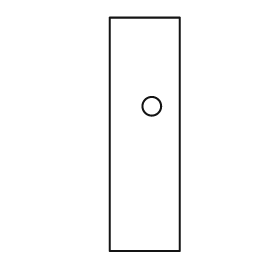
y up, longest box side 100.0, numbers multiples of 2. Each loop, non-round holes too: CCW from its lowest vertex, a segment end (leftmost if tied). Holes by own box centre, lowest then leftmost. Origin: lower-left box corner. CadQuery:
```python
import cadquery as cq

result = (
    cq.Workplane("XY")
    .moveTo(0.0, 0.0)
    .lineTo(30.0, 0.0)
    .lineTo(30.0, 100.0)
    .lineTo(0.0, 100.0)
    .close()
    .moveTo(18.0, 62.0)
    .circle(4.0)
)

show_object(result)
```